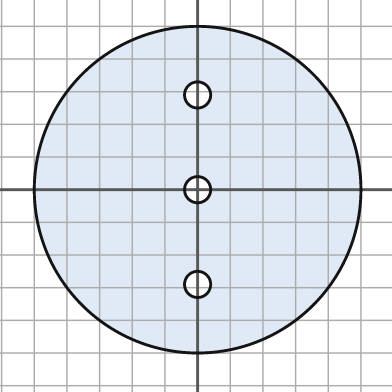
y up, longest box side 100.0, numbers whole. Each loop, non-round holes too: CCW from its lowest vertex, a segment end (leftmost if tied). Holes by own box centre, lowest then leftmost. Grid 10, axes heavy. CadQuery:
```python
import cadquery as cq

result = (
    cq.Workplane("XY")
    .moveTo(0.0, 0.0)
    .circle(50.0)
    .moveTo(0.0, -29.0)
    .circle(4.0)
    .moveTo(0.0, 0.0)
    .circle(4.0)
    .moveTo(0.0, 29.0)
    .circle(4.0)
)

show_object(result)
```